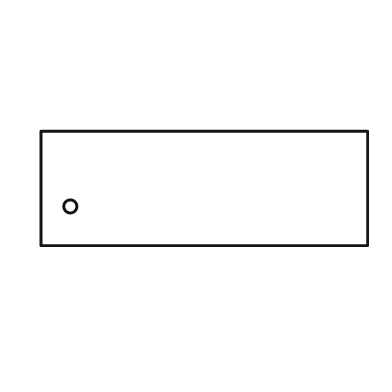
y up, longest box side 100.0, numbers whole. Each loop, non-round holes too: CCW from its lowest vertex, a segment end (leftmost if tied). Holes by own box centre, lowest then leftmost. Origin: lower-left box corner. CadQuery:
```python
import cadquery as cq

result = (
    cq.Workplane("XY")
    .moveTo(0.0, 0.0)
    .lineTo(100.0, 0.0)
    .lineTo(100.0, 35.0)
    .lineTo(0.0, 35.0)
    .close()
    .moveTo(9.0, 12.0)
    .circle(2.0)
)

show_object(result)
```